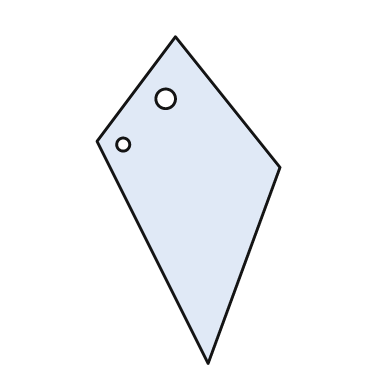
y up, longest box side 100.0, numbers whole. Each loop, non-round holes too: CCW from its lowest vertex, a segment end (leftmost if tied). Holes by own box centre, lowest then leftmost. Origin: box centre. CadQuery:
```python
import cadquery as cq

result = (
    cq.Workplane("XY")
    .moveTo(6.0, -50.0)
    .lineTo(28.0, 10.0)
    .lineTo(-4.0, 50.0)
    .lineTo(-28.0, 18.0)
    .close()
    .moveTo(-20.0, 17.0)
    .circle(2.0)
    .moveTo(-7.0, 31.0)
    .circle(3.0)
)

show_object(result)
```